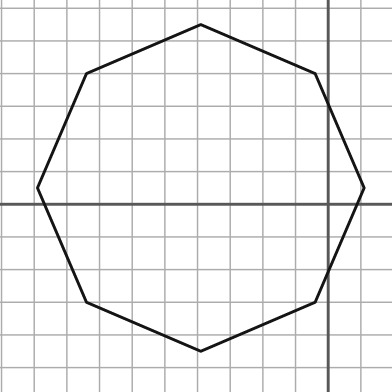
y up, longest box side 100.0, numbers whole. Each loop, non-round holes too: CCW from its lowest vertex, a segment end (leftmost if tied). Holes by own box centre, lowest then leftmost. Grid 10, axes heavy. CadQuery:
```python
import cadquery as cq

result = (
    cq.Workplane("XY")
    .moveTo(-39.0, -45.0)
    .lineTo(-4.0, -30.0)
    .lineTo(11.0, 5.0)
    .lineTo(-4.0, 40.0)
    .lineTo(-39.0, 55.0)
    .lineTo(-74.0, 40.0)
    .lineTo(-89.0, 5.0)
    .lineTo(-74.0, -30.0)
    .close()
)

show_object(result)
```